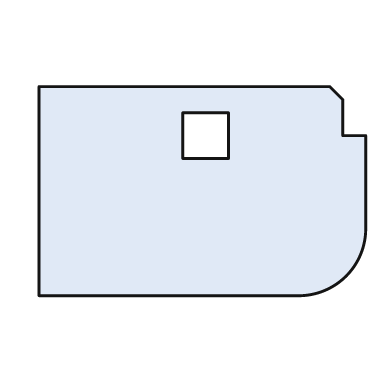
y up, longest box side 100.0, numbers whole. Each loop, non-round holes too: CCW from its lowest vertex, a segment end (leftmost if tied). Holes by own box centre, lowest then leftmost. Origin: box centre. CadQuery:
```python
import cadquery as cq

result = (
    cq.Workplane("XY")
    .moveTo(-50.0, -32.0)
    .lineTo(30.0, -32.0)
    .threePointArc((44.0, -26.0), (50.0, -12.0))
    .lineTo(50.0, 17.0)
    .lineTo(43.0, 17.0)
    .lineTo(43.0, 28.0)
    .lineTo(39.0, 32.0)
    .lineTo(-50.0, 32.0)
    .close()
    .moveTo(-6.0, 10.0)
    .lineTo(8.0, 10.0)
    .lineTo(8.0, 24.0)
    .lineTo(-6.0, 24.0)
    .close()
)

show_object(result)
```